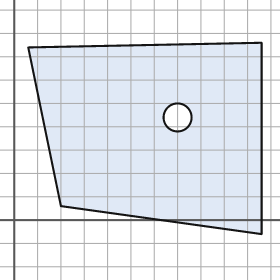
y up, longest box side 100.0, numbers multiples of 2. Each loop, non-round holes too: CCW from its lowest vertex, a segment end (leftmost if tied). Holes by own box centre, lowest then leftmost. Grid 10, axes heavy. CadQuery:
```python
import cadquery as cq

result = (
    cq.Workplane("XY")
    .moveTo(106.0, -6.0)
    .lineTo(106.0, 76.0)
    .lineTo(6.0, 74.0)
    .lineTo(20.0, 6.0)
    .close()
    .moveTo(70.0, 44.0)
    .circle(6.0)
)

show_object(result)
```